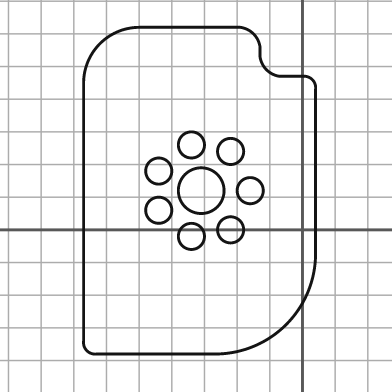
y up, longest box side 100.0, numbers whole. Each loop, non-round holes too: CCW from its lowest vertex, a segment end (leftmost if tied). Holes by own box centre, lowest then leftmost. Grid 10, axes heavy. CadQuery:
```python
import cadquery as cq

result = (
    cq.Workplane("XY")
    .moveTo(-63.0, -38.0)
    .lineTo(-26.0, -38.0)
    .threePointArc((-5.0, -29.0), (4.0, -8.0))
    .lineTo(4.0, 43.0)
    .threePointArc((3.0, 46.0), (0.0, 47.0))
    .lineTo(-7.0, 47.0)
    .threePointArc((-11.0, 49.0), (-13.0, 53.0))
    .lineTo(-13.0, 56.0)
    .threePointArc((-15.0, 60.0), (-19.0, 62.0))
    .lineTo(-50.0, 62.0)
    .threePointArc((-62.0, 57.0), (-67.0, 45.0))
    .lineTo(-67.0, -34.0)
    .threePointArc((-66.0, -37.0), (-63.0, -38.0))
    .close()
    .moveTo(-34.0, -2.0)
    .circle(4.0)
    .moveTo(-22.0, 0.0)
    .circle(4.0)
    .moveTo(-44.0, 6.0)
    .circle(4.0)
    .moveTo(-31.0, 12.0)
    .circle(7.0)
    .moveTo(-16.0, 12.0)
    .circle(4.0)
    .moveTo(-44.0, 18.0)
    .circle(4.0)
    .moveTo(-22.0, 24.0)
    .circle(4.0)
    .moveTo(-34.0, 26.0)
    .circle(4.0)
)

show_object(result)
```